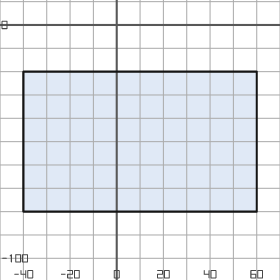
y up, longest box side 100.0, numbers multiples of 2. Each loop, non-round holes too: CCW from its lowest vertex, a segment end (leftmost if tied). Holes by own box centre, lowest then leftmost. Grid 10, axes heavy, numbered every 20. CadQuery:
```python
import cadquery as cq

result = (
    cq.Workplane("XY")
    .moveTo(-40.0, -80.0)
    .lineTo(60.0, -80.0)
    .lineTo(60.0, -20.0)
    .lineTo(-40.0, -20.0)
    .close()
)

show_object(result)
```